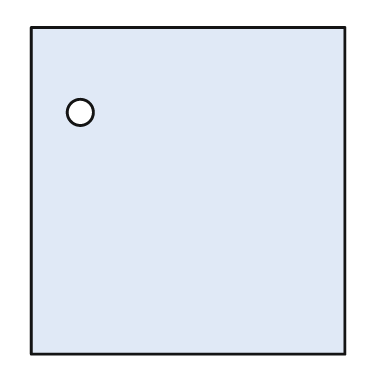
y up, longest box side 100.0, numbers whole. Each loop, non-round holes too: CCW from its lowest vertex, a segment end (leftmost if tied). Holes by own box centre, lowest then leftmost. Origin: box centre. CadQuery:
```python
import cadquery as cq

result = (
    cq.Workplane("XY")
    .moveTo(-48.0, -50.0)
    .lineTo(48.0, -50.0)
    .lineTo(48.0, 50.0)
    .lineTo(-48.0, 50.0)
    .close()
    .moveTo(-33.0, 24.0)
    .circle(4.0)
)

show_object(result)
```